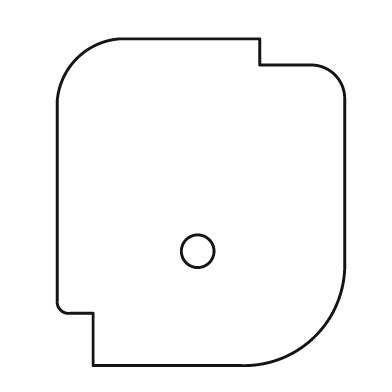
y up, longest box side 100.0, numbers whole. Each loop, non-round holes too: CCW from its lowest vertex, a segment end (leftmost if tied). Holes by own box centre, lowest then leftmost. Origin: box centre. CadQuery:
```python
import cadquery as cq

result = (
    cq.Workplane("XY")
    .moveTo(-33.0, -50.0)
    .lineTo(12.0, -50.0)
    .threePointArc((35.0, -41.0), (44.0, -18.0))
    .lineTo(44.0, 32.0)
    .threePointArc((41.0, 39.0), (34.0, 42.0))
    .lineTo(18.0, 42.0)
    .lineTo(18.0, 50.0)
    .lineTo(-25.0, 50.0)
    .threePointArc((-38.0, 44.0), (-44.0, 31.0))
    .lineTo(-44.0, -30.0)
    .threePointArc((-43.0, -33.0), (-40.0, -34.0))
    .lineTo(-33.0, -34.0)
    .close()
    .moveTo(-1.0, -15.0)
    .circle(5.0)
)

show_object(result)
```